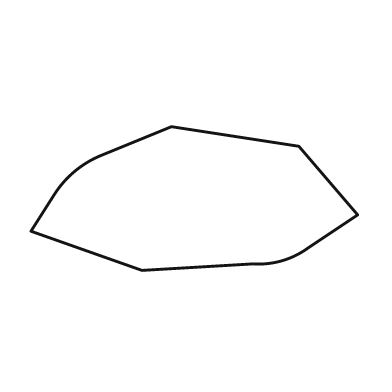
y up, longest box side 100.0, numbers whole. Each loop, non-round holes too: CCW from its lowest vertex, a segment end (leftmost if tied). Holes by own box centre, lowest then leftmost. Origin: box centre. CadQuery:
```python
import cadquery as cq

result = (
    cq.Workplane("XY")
    .moveTo(-16.0, -22.0)
    .lineTo(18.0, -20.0)
    .threePointArc((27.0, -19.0), (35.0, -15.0))
    .lineTo(50.0, -5.0)
    .lineTo(32.0, 16.0)
    .lineTo(-7.0, 22.0)
    .lineTo(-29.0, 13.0)
    .threePointArc((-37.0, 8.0), (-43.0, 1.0))
    .lineTo(-50.0, -10.0)
    .close()
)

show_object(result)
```